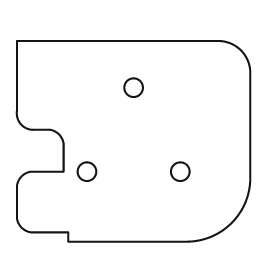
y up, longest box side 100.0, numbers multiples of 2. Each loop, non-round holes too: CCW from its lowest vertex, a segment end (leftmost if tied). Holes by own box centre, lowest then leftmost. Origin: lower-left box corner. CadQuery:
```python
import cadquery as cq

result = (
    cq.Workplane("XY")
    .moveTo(22.0, 0.0)
    .lineTo(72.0, 0.0)
    .threePointArc((92.0, 8.0), (100.0, 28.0))
    .lineTo(100.0, 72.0)
    .threePointArc((96.0, 82.0), (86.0, 86.0))
    .lineTo(0.0, 86.0)
    .lineTo(0.0, 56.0)
    .threePointArc((2.0, 50.0), (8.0, 48.0))
    .lineTo(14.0, 48.0)
    .threePointArc((18.0, 46.0), (20.0, 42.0))
    .lineTo(20.0, 30.0)
    .lineTo(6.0, 30.0)
    .threePointArc((2.0, 28.0), (0.0, 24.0))
    .lineTo(0.0, 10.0)
    .threePointArc((2.0, 6.0), (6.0, 4.0))
    .lineTo(22.0, 4.0)
    .close()
    .moveTo(30.0, 30.0)
    .circle(4.0)
    .moveTo(70.0, 30.0)
    .circle(4.0)
    .moveTo(50.0, 66.0)
    .circle(4.0)
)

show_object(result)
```